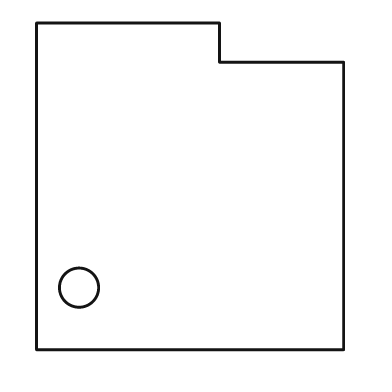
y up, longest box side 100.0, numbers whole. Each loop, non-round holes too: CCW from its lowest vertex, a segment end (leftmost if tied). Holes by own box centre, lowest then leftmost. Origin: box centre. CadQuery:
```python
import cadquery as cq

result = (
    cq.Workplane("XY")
    .moveTo(-47.0, -50.0)
    .lineTo(47.0, -50.0)
    .lineTo(47.0, 38.0)
    .lineTo(9.0, 38.0)
    .lineTo(9.0, 50.0)
    .lineTo(-47.0, 50.0)
    .close()
    .moveTo(-34.0, -31.0)
    .circle(6.0)
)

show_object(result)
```